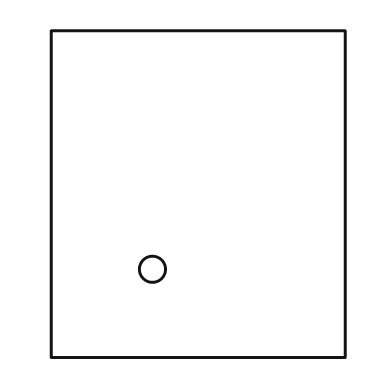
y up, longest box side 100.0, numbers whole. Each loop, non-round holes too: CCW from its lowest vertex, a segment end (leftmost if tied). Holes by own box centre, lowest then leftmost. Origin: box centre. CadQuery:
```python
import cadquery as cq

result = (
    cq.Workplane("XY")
    .moveTo(-45.0, -50.0)
    .lineTo(45.0, -50.0)
    .lineTo(45.0, 50.0)
    .lineTo(-45.0, 50.0)
    .close()
    .moveTo(-14.0, -23.0)
    .circle(4.0)
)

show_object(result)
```